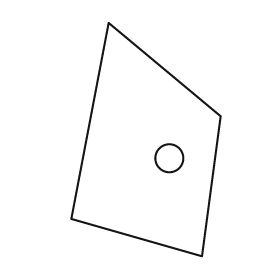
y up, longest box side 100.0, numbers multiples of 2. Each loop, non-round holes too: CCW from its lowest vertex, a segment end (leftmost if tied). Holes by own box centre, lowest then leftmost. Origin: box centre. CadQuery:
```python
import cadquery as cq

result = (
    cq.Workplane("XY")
    .moveTo(24.0, -50.0)
    .lineTo(32.0, 10.0)
    .lineTo(-16.0, 50.0)
    .lineTo(-32.0, -34.0)
    .close()
    .moveTo(10.0, -8.0)
    .circle(6.0)
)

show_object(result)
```